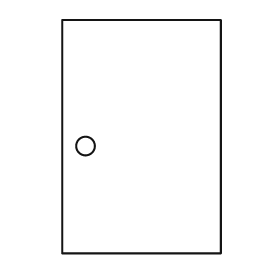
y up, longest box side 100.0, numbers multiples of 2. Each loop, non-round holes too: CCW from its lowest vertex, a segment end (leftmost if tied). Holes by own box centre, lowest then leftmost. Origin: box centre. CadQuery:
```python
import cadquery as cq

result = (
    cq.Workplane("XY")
    .moveTo(-34.0, -50.0)
    .lineTo(34.0, -50.0)
    .lineTo(34.0, 50.0)
    .lineTo(-34.0, 50.0)
    .close()
    .moveTo(-24.0, -4.0)
    .circle(4.0)
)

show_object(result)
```